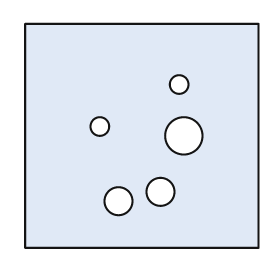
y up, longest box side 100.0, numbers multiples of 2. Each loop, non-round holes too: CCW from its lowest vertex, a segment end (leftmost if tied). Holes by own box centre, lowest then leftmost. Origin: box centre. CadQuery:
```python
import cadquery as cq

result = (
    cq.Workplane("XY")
    .moveTo(-50.0, -48.0)
    .lineTo(50.0, -48.0)
    .lineTo(50.0, 48.0)
    .lineTo(-50.0, 48.0)
    .close()
    .moveTo(-10.0, -28.0)
    .circle(6.0)
    .moveTo(8.0, -24.0)
    .circle(6.0)
    .moveTo(18.0, 0.0)
    .circle(8.0)
    .moveTo(-18.0, 4.0)
    .circle(4.0)
    .moveTo(16.0, 22.0)
    .circle(4.0)
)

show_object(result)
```